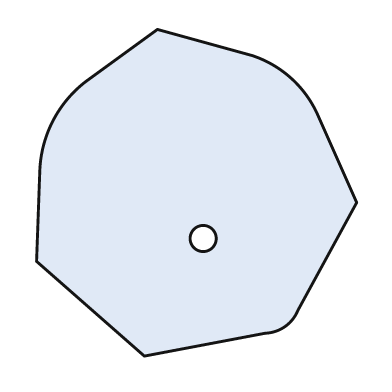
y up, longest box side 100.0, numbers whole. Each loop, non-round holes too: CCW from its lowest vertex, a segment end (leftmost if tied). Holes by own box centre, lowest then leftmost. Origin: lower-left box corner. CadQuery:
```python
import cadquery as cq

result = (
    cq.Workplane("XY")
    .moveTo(33.0, 0.0)
    .lineTo(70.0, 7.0)
    .threePointArc((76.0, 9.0), (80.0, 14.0))
    .lineTo(98.0, 47.0)
    .lineTo(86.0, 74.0)
    .threePointArc((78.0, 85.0), (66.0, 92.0))
    .lineTo(37.0, 100.0)
    .lineTo(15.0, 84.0)
    .threePointArc((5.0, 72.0), (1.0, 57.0))
    .lineTo(0.0, 29.0)
    .close()
    .moveTo(51.0, 36.0)
    .circle(4.0)
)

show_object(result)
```